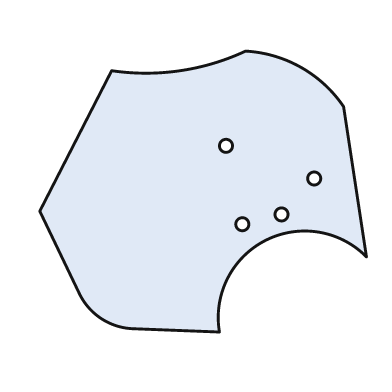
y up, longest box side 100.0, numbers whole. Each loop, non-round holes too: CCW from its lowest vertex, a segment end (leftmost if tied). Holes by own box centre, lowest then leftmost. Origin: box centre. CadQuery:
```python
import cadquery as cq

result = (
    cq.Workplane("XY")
    .moveTo(5.0, -43.0)
    .threePointArc((19.0, -15.0), (50.0, -20.0))
    .lineTo(43.0, 26.0)
    .threePointArc((30.0, 38.0), (13.0, 43.0))
    .threePointArc((-7.0, 37.0), (-28.0, 37.0))
    .lineTo(-50.0, -6.0)
    .lineTo(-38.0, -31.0)
    .threePointArc((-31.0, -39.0), (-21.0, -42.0))
    .close()
    .moveTo(12.0, -10.0)
    .circle(2.0)
    .moveTo(24.0, -7.0)
    .circle(2.0)
    .moveTo(34.0, 4.0)
    .circle(2.0)
    .moveTo(7.0, 14.0)
    .circle(2.0)
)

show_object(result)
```